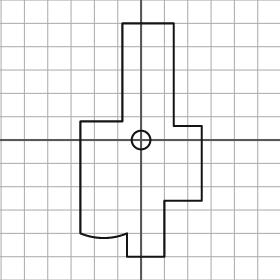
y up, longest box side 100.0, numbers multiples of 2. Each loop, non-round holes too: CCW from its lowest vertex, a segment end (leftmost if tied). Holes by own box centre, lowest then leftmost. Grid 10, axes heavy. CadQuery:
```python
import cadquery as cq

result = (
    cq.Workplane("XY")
    .moveTo(-6.0, -50.0)
    .lineTo(10.0, -50.0)
    .lineTo(10.0, -26.0)
    .lineTo(26.0, -26.0)
    .lineTo(26.0, 6.0)
    .lineTo(14.0, 6.0)
    .lineTo(14.0, 50.0)
    .lineTo(-8.0, 50.0)
    .lineTo(-8.0, 8.0)
    .lineTo(-26.0, 8.0)
    .lineTo(-26.0, -40.0)
    .threePointArc((-16.0, -42.0), (-6.0, -40.0))
    .close()
    .moveTo(0.0, 0.0)
    .circle(4.0)
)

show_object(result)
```